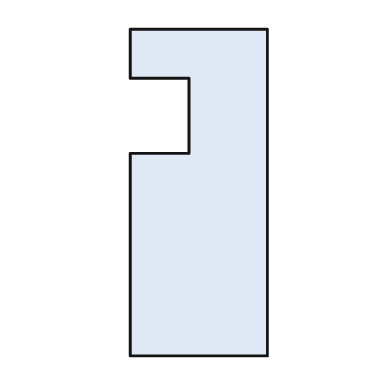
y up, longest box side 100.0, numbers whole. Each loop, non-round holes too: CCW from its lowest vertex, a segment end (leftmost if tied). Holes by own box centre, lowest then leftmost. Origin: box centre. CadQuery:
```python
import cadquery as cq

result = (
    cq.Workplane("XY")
    .moveTo(-21.0, -50.0)
    .lineTo(21.0, -50.0)
    .lineTo(21.0, 50.0)
    .lineTo(-21.0, 50.0)
    .lineTo(-21.0, 35.0)
    .lineTo(-3.0, 35.0)
    .lineTo(-3.0, 12.0)
    .lineTo(-21.0, 12.0)
    .close()
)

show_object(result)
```